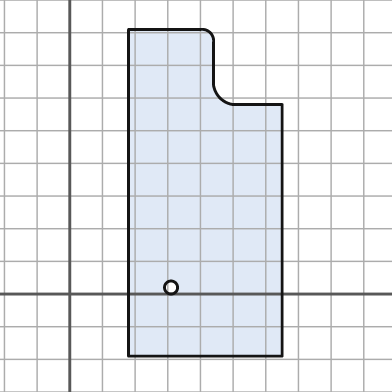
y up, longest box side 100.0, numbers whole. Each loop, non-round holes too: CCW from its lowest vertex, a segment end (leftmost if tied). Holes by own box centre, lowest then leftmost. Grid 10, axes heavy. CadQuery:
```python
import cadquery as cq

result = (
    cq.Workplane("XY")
    .moveTo(18.0, -19.0)
    .lineTo(65.0, -19.0)
    .lineTo(65.0, 58.0)
    .lineTo(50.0, 58.0)
    .threePointArc((46.0, 60.0), (44.0, 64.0))
    .lineTo(44.0, 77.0)
    .threePointArc((43.0, 80.0), (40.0, 81.0))
    .lineTo(18.0, 81.0)
    .close()
    .moveTo(31.0, 2.0)
    .circle(2.0)
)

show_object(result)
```